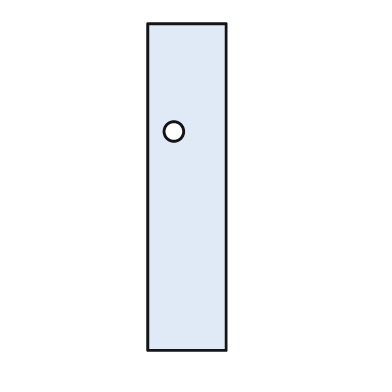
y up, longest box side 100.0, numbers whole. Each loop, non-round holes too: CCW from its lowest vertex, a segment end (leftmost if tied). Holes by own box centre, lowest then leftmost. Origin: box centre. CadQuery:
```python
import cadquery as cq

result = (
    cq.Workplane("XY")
    .moveTo(-12.0, -50.0)
    .lineTo(12.0, -50.0)
    .lineTo(12.0, 50.0)
    .lineTo(-12.0, 50.0)
    .close()
    .moveTo(-4.0, 17.0)
    .circle(3.0)
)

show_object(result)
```